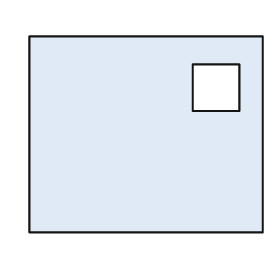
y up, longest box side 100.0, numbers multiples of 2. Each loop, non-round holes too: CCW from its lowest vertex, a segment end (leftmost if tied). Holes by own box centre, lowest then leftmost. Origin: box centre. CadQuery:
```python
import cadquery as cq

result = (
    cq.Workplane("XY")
    .moveTo(-50.0, -42.0)
    .lineTo(50.0, -42.0)
    .lineTo(50.0, 42.0)
    .lineTo(-50.0, 42.0)
    .close()
    .moveTo(20.0, 10.0)
    .lineTo(40.0, 10.0)
    .lineTo(40.0, 30.0)
    .lineTo(20.0, 30.0)
    .close()
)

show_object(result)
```